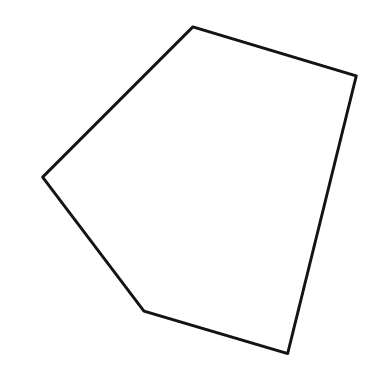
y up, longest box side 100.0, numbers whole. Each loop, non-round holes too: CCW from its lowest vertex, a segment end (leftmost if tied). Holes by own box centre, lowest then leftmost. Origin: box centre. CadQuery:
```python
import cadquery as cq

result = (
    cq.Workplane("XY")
    .moveTo(27.0, -50.0)
    .lineTo(48.0, 35.0)
    .lineTo(-2.0, 50.0)
    .lineTo(-48.0, 4.0)
    .lineTo(-17.0, -37.0)
    .close()
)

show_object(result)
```